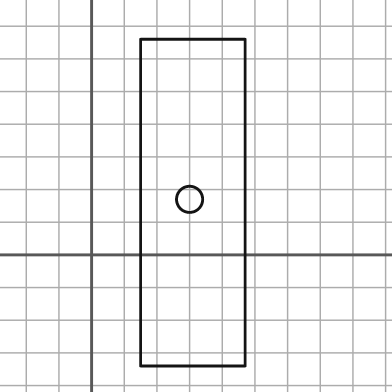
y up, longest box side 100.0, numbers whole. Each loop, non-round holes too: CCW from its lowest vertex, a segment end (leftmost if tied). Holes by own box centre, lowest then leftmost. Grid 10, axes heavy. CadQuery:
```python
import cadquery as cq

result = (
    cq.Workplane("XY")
    .moveTo(15.0, -34.0)
    .lineTo(47.0, -34.0)
    .lineTo(47.0, 66.0)
    .lineTo(15.0, 66.0)
    .close()
    .moveTo(30.0, 17.0)
    .circle(4.0)
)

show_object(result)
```